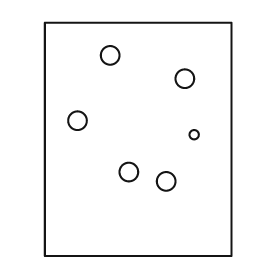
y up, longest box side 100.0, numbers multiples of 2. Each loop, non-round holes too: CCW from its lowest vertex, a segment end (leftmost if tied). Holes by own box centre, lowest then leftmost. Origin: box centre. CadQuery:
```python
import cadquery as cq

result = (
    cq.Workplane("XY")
    .moveTo(-40.0, -50.0)
    .lineTo(40.0, -50.0)
    .lineTo(40.0, 50.0)
    .lineTo(-40.0, 50.0)
    .close()
    .moveTo(12.0, -18.0)
    .circle(4.0)
    .moveTo(-4.0, -14.0)
    .circle(4.0)
    .moveTo(24.0, 2.0)
    .circle(2.0)
    .moveTo(-26.0, 8.0)
    .circle(4.0)
    .moveTo(20.0, 26.0)
    .circle(4.0)
    .moveTo(-12.0, 36.0)
    .circle(4.0)
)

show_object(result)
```